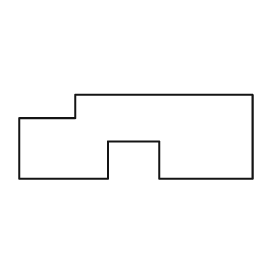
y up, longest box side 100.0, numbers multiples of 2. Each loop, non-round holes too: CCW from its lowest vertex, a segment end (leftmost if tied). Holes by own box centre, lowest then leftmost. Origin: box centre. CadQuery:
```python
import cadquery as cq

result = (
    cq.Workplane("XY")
    .moveTo(-50.0, -18.0)
    .lineTo(-12.0, -18.0)
    .lineTo(-12.0, -2.0)
    .lineTo(10.0, -2.0)
    .lineTo(10.0, -18.0)
    .lineTo(50.0, -18.0)
    .lineTo(50.0, 18.0)
    .lineTo(-26.0, 18.0)
    .lineTo(-26.0, 8.0)
    .lineTo(-50.0, 8.0)
    .close()
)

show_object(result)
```